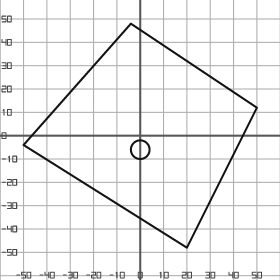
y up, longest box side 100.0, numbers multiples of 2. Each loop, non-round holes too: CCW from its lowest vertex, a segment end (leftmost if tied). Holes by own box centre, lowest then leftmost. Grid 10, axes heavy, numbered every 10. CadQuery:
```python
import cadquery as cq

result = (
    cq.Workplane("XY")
    .moveTo(20.0, -48.0)
    .lineTo(50.0, 12.0)
    .lineTo(-4.0, 48.0)
    .lineTo(-50.0, -4.0)
    .close()
    .moveTo(0.0, -6.0)
    .circle(4.0)
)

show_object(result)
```